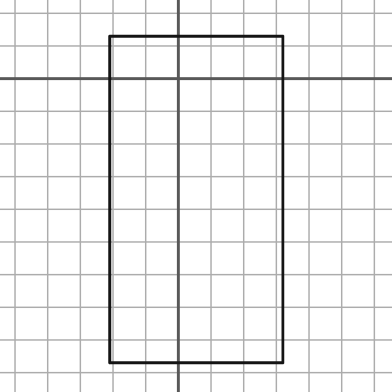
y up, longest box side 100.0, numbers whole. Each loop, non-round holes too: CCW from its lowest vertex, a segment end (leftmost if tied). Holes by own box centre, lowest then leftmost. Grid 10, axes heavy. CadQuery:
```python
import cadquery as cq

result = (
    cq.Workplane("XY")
    .moveTo(-21.0, -87.0)
    .lineTo(32.0, -87.0)
    .lineTo(32.0, 13.0)
    .lineTo(-21.0, 13.0)
    .close()
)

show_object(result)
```